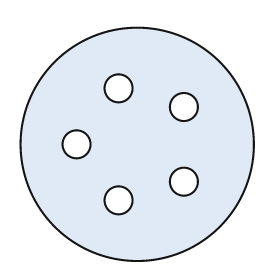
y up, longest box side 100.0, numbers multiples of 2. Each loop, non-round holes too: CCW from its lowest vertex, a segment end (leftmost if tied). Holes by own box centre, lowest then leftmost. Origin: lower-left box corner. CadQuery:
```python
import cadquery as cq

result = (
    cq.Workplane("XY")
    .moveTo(50.0, 50.0)
    .circle(50.0)
    .moveTo(42.0, 26.0)
    .circle(6.0)
    .moveTo(70.0, 34.0)
    .circle(6.0)
    .moveTo(24.0, 50.0)
    .circle(6.0)
    .moveTo(70.0, 66.0)
    .circle(6.0)
    .moveTo(42.0, 74.0)
    .circle(6.0)
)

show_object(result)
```